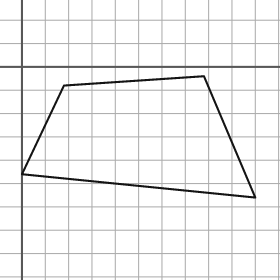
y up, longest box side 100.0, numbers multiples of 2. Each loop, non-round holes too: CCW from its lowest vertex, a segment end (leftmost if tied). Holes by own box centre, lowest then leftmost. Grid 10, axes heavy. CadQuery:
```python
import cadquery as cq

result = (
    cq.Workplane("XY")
    .moveTo(100.0, -56.0)
    .lineTo(78.0, -4.0)
    .lineTo(18.0, -8.0)
    .lineTo(0.0, -46.0)
    .close()
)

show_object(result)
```